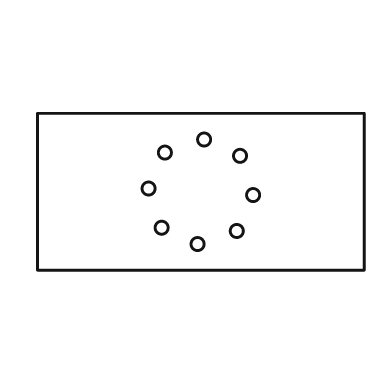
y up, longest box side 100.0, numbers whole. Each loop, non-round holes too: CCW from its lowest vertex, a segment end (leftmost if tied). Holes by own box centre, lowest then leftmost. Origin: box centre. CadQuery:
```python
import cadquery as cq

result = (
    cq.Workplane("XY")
    .moveTo(-50.0, -24.0)
    .lineTo(50.0, -24.0)
    .lineTo(50.0, 24.0)
    .lineTo(-50.0, 24.0)
    .close()
    .moveTo(-1.0, -16.0)
    .circle(2.0)
    .moveTo(11.0, -12.0)
    .circle(2.0)
    .moveTo(-12.0, -11.0)
    .circle(2.0)
    .moveTo(16.0, -1.0)
    .circle(2.0)
    .moveTo(-16.0, 1.0)
    .circle(2.0)
    .moveTo(12.0, 11.0)
    .circle(2.0)
    .moveTo(-11.0, 12.0)
    .circle(2.0)
    .moveTo(1.0, 16.0)
    .circle(2.0)
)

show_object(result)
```